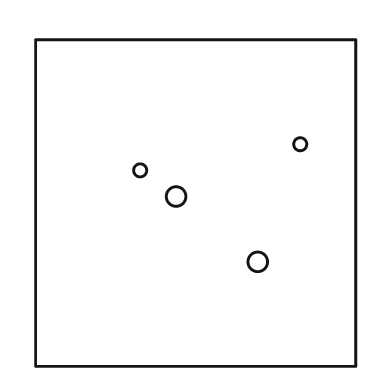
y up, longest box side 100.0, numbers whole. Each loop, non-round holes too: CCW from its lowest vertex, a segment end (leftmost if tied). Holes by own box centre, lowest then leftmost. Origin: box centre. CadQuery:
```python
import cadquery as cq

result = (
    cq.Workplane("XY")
    .moveTo(-49.0, -50.0)
    .lineTo(49.0, -50.0)
    .lineTo(49.0, 50.0)
    .lineTo(-49.0, 50.0)
    .close()
    .moveTo(19.0, -18.0)
    .circle(3.0)
    .moveTo(-6.0, 2.0)
    .circle(3.0)
    .moveTo(-17.0, 10.0)
    .circle(2.0)
    .moveTo(32.0, 18.0)
    .circle(2.0)
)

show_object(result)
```